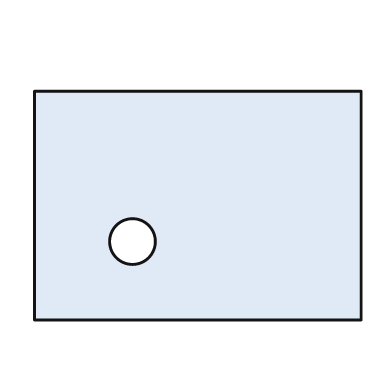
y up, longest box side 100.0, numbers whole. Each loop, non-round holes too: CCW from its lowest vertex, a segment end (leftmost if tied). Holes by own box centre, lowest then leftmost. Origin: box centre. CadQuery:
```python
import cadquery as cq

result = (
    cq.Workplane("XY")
    .moveTo(-50.0, -35.0)
    .lineTo(50.0, -35.0)
    .lineTo(50.0, 35.0)
    .lineTo(-50.0, 35.0)
    .close()
    .moveTo(-20.0, -11.0)
    .circle(7.0)
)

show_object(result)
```